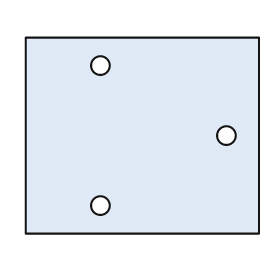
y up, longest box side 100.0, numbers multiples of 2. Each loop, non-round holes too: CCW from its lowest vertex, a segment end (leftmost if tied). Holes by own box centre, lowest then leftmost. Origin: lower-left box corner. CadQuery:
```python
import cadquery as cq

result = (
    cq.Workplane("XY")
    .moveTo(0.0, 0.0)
    .lineTo(100.0, 0.0)
    .lineTo(100.0, 84.0)
    .lineTo(0.0, 84.0)
    .close()
    .moveTo(32.0, 12.0)
    .circle(4.0)
    .moveTo(86.0, 42.0)
    .circle(4.0)
    .moveTo(32.0, 72.0)
    .circle(4.0)
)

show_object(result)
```